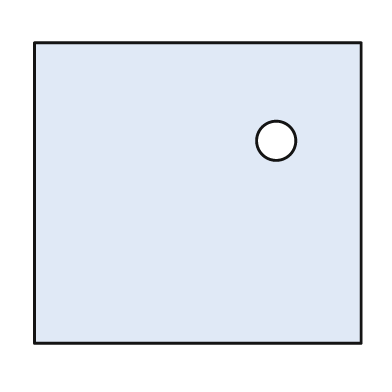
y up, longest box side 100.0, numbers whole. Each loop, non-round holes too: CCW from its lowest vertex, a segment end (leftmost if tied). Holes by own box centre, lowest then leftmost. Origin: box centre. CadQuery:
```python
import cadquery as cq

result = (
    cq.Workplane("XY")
    .moveTo(-50.0, -46.0)
    .lineTo(50.0, -46.0)
    .lineTo(50.0, 46.0)
    .lineTo(-50.0, 46.0)
    .close()
    .moveTo(24.0, 16.0)
    .circle(6.0)
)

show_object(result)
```